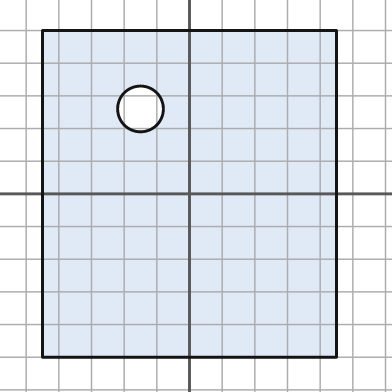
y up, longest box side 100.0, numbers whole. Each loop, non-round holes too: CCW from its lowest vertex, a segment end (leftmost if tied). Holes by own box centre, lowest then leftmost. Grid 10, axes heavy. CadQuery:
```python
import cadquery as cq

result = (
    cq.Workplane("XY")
    .moveTo(-45.0, -50.0)
    .lineTo(45.0, -50.0)
    .lineTo(45.0, 50.0)
    .lineTo(-45.0, 50.0)
    .close()
    .moveTo(-15.0, 26.0)
    .circle(7.0)
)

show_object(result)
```